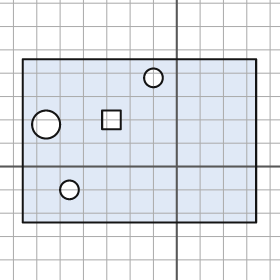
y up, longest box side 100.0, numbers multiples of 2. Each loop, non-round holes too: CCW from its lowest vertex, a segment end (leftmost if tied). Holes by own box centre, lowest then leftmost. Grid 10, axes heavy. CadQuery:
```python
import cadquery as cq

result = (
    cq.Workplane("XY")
    .moveTo(-66.0, -24.0)
    .lineTo(34.0, -24.0)
    .lineTo(34.0, 46.0)
    .lineTo(-66.0, 46.0)
    .close()
    .moveTo(-46.0, -10.0)
    .circle(4.0)
    .moveTo(-56.0, 18.0)
    .circle(6.0)
    .moveTo(-32.0, 16.0)
    .lineTo(-24.0, 16.0)
    .lineTo(-24.0, 24.0)
    .lineTo(-32.0, 24.0)
    .close()
    .moveTo(-10.0, 38.0)
    .circle(4.0)
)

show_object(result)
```